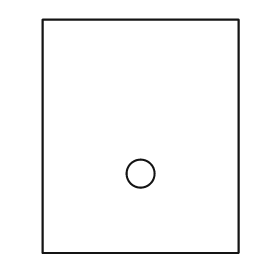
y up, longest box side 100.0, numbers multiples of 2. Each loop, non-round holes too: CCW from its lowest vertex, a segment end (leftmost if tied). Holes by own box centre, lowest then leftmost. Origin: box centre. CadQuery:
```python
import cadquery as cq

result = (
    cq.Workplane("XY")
    .moveTo(-42.0, -50.0)
    .lineTo(42.0, -50.0)
    .lineTo(42.0, 50.0)
    .lineTo(-42.0, 50.0)
    .close()
    .moveTo(0.0, -16.0)
    .circle(6.0)
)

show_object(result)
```